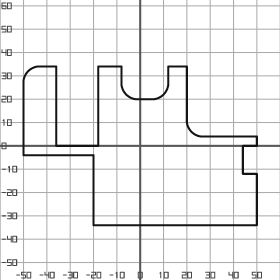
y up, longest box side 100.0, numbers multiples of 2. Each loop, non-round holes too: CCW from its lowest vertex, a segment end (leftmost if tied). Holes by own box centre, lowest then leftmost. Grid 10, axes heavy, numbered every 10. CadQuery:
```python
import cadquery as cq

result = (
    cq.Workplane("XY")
    .moveTo(-20.0, -34.0)
    .lineTo(50.0, -34.0)
    .lineTo(50.0, -12.0)
    .lineTo(44.0, -12.0)
    .lineTo(44.0, 0.0)
    .lineTo(50.0, 0.0)
    .lineTo(50.0, 4.0)
    .lineTo(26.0, 4.0)
    .threePointArc((22.0, 6.0), (20.0, 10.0))
    .lineTo(20.0, 34.0)
    .lineTo(12.0, 34.0)
    .lineTo(12.0, 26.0)
    .threePointArc((10.0, 22.0), (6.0, 20.0))
    .lineTo(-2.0, 20.0)
    .threePointArc((-6.0, 22.0), (-8.0, 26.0))
    .lineTo(-8.0, 34.0)
    .lineTo(-18.0, 34.0)
    .lineTo(-18.0, 0.0)
    .lineTo(-36.0, 0.0)
    .lineTo(-36.0, 34.0)
    .lineTo(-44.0, 34.0)
    .threePointArc((-48.0, 32.0), (-50.0, 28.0))
    .lineTo(-50.0, -4.0)
    .lineTo(-20.0, -4.0)
    .close()
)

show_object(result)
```